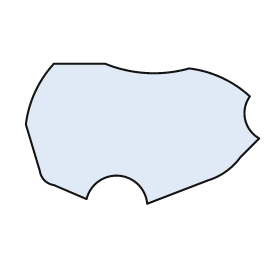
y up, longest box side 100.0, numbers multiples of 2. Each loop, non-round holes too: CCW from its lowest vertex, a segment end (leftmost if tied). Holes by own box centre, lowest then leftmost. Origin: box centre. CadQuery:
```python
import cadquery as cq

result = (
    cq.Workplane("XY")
    .moveTo(2.0, -30.0)
    .lineTo(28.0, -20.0)
    .threePointArc((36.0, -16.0), (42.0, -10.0))
    .lineTo(50.0, -2.0)
    .threePointArc((44.0, 6.0), (46.0, 16.0))
    .threePointArc((34.0, 24.0), (20.0, 28.0))
    .threePointArc((2.0, 26.0), (-16.0, 30.0))
    .lineTo(-38.0, 30.0)
    .threePointArc((-46.0, 18.0), (-50.0, 4.0))
    .lineTo(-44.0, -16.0)
    .threePointArc((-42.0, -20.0), (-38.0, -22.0))
    .lineTo(-24.0, -28.0)
    .threePointArc((-10.0, -18.0), (2.0, -30.0))
    .close()
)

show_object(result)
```